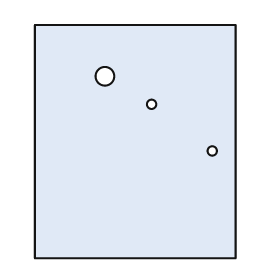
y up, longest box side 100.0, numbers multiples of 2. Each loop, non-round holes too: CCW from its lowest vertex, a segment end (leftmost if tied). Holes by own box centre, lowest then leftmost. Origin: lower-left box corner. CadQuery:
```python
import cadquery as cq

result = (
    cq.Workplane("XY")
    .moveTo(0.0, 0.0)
    .lineTo(86.0, 0.0)
    .lineTo(86.0, 100.0)
    .lineTo(0.0, 100.0)
    .close()
    .moveTo(76.0, 46.0)
    .circle(2.0)
    .moveTo(50.0, 66.0)
    .circle(2.0)
    .moveTo(30.0, 78.0)
    .circle(4.0)
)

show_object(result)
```